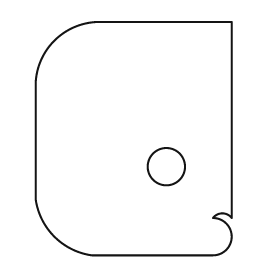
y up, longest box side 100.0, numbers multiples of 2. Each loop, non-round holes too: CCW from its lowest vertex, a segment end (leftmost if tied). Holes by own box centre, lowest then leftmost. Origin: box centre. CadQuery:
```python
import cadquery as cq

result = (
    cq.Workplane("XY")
    .moveTo(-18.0, -50.0)
    .lineTo(34.0, -50.0)
    .threePointArc((42.0, -42.0), (34.0, -34.0))
    .threePointArc((38.0, -32.0), (42.0, -34.0))
    .lineTo(42.0, 50.0)
    .lineTo(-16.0, 50.0)
    .threePointArc((-34.0, 42.0), (-42.0, 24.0))
    .lineTo(-42.0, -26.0)
    .threePointArc((-34.0, -42.0), (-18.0, -50.0))
    .close()
    .moveTo(14.0, -12.0)
    .circle(8.0)
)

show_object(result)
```